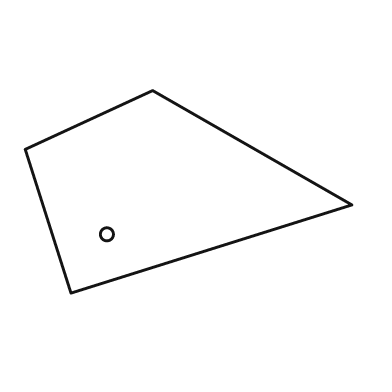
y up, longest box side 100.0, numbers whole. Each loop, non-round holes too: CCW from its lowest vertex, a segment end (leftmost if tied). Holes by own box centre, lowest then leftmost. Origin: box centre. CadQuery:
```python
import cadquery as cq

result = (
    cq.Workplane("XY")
    .moveTo(-36.0, -31.0)
    .lineTo(50.0, -4.0)
    .lineTo(-11.0, 31.0)
    .lineTo(-50.0, 13.0)
    .close()
    .moveTo(-25.0, -13.0)
    .circle(2.0)
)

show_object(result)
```